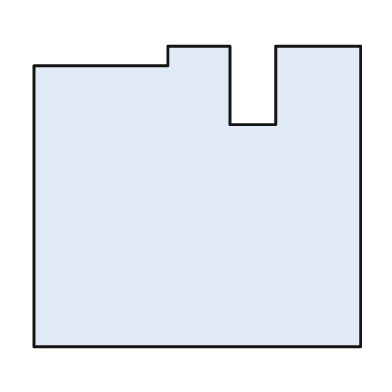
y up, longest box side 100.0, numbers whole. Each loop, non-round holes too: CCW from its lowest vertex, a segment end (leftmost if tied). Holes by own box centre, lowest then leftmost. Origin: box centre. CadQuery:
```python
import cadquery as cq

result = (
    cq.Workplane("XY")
    .moveTo(-50.0, -46.0)
    .lineTo(50.0, -46.0)
    .lineTo(50.0, 46.0)
    .lineTo(24.0, 46.0)
    .lineTo(24.0, 22.0)
    .lineTo(10.0, 22.0)
    .lineTo(10.0, 46.0)
    .lineTo(-9.0, 46.0)
    .lineTo(-9.0, 40.0)
    .lineTo(-50.0, 40.0)
    .close()
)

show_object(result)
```